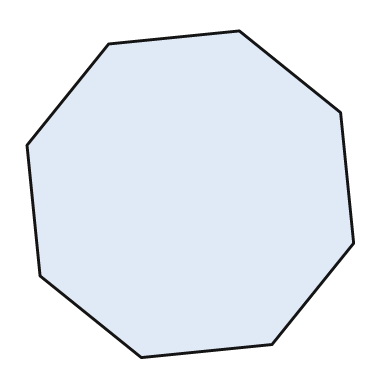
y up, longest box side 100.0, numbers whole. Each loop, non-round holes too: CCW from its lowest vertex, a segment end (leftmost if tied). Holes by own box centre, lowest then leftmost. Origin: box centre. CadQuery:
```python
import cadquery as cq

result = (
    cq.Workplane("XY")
    .moveTo(-15.0, -50.0)
    .lineTo(25.0, -46.0)
    .lineTo(50.0, -15.0)
    .lineTo(46.0, 25.0)
    .lineTo(15.0, 50.0)
    .lineTo(-25.0, 46.0)
    .lineTo(-50.0, 15.0)
    .lineTo(-46.0, -25.0)
    .close()
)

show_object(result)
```